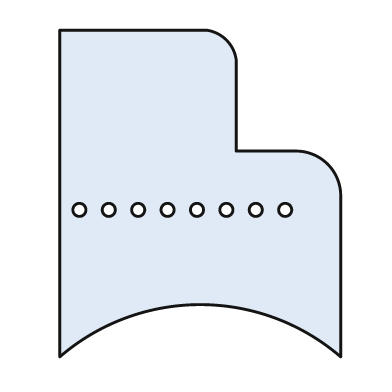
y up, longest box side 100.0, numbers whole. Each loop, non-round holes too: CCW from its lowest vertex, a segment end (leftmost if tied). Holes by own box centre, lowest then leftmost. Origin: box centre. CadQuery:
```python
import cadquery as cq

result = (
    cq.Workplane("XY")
    .moveTo(-43.0, -50.0)
    .threePointArc((0.0, -34.0), (43.0, -50.0))
    .lineTo(43.0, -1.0)
    .threePointArc((39.0, 9.0), (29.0, 13.0))
    .lineTo(11.0, 13.0)
    .lineTo(11.0, 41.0)
    .threePointArc((8.0, 47.0), (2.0, 50.0))
    .lineTo(-43.0, 50.0)
    .close()
    .moveTo(-37.0, -5.0)
    .circle(2.0)
    .moveTo(-28.0, -5.0)
    .circle(2.0)
    .moveTo(-19.0, -5.0)
    .circle(2.0)
    .moveTo(-10.0, -5.0)
    .circle(2.0)
    .moveTo(-1.0, -5.0)
    .circle(2.0)
    .moveTo(8.0, -5.0)
    .circle(2.0)
    .moveTo(17.0, -5.0)
    .circle(2.0)
    .moveTo(26.0, -5.0)
    .circle(2.0)
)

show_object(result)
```